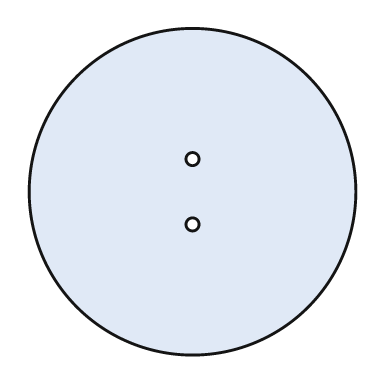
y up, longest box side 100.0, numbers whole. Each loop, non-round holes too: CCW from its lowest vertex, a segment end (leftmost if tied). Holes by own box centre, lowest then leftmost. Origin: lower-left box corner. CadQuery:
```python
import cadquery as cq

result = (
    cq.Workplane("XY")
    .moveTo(50.0, 50.0)
    .circle(50.0)
    .moveTo(50.0, 40.0)
    .circle(2.0)
    .moveTo(50.0, 60.0)
    .circle(2.0)
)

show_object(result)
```